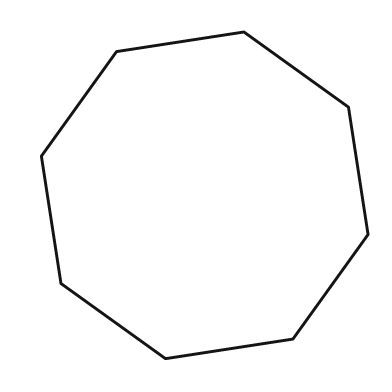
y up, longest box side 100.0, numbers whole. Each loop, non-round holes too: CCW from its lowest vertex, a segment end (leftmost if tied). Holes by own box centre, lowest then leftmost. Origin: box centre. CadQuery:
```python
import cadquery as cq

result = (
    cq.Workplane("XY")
    .moveTo(-12.0, -50.0)
    .lineTo(27.0, -44.0)
    .lineTo(50.0, -12.0)
    .lineTo(44.0, 27.0)
    .lineTo(12.0, 50.0)
    .lineTo(-27.0, 44.0)
    .lineTo(-50.0, 12.0)
    .lineTo(-44.0, -27.0)
    .close()
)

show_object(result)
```